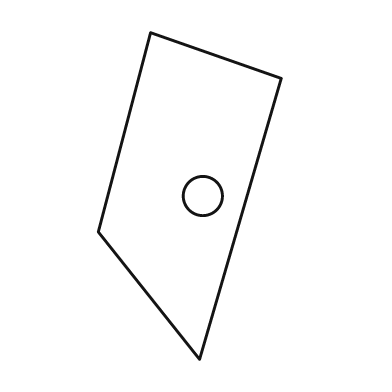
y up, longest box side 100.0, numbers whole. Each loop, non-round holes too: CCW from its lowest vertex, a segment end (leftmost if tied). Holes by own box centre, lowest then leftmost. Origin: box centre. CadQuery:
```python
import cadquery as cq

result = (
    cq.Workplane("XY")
    .moveTo(3.0, -50.0)
    .lineTo(28.0, 36.0)
    .lineTo(-12.0, 50.0)
    .lineTo(-28.0, -11.0)
    .close()
    .moveTo(4.0, 0.0)
    .circle(6.0)
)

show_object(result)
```